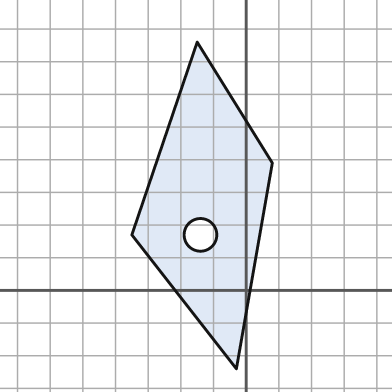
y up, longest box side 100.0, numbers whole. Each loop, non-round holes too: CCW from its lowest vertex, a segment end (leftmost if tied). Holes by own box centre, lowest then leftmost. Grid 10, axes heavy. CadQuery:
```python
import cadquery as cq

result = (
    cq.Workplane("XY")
    .moveTo(-3.0, -24.0)
    .lineTo(8.0, 39.0)
    .lineTo(-15.0, 76.0)
    .lineTo(-35.0, 17.0)
    .close()
    .moveTo(-14.0, 17.0)
    .circle(5.0)
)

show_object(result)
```